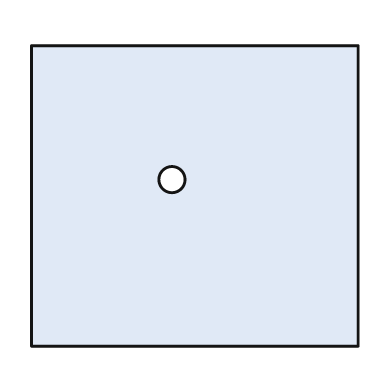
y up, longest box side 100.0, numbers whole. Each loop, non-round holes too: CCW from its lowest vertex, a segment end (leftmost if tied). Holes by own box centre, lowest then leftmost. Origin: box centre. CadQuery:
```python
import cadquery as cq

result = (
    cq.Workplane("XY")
    .moveTo(-50.0, -46.0)
    .lineTo(50.0, -46.0)
    .lineTo(50.0, 46.0)
    .lineTo(-50.0, 46.0)
    .close()
    .moveTo(-7.0, 5.0)
    .circle(4.0)
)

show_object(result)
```